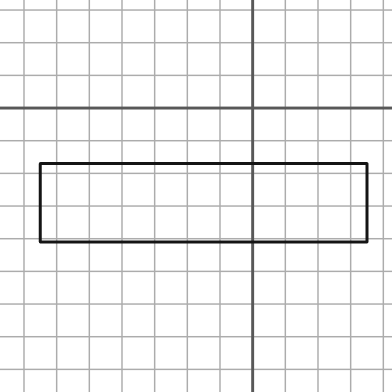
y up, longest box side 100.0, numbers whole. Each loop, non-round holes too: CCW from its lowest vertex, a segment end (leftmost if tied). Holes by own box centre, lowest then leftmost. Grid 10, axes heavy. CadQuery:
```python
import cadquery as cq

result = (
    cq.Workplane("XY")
    .moveTo(-65.0, -41.0)
    .lineTo(35.0, -41.0)
    .lineTo(35.0, -17.0)
    .lineTo(-65.0, -17.0)
    .close()
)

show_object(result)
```